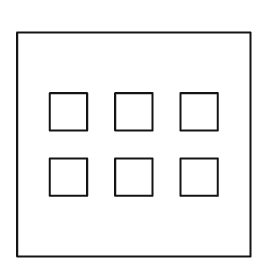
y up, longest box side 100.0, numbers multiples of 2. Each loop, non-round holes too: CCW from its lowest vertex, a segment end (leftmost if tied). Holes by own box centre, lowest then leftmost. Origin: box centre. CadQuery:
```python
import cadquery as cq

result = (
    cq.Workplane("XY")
    .moveTo(-50.0, -48.0)
    .lineTo(50.0, -48.0)
    .lineTo(50.0, 48.0)
    .lineTo(-50.0, 48.0)
    .close()
    .moveTo(-36.0, -22.0)
    .lineTo(-20.0, -22.0)
    .lineTo(-20.0, -6.0)
    .lineTo(-36.0, -6.0)
    .close()
    .moveTo(-8.0, -22.0)
    .lineTo(8.0, -22.0)
    .lineTo(8.0, -6.0)
    .lineTo(-8.0, -6.0)
    .close()
    .moveTo(20.0, -22.0)
    .lineTo(36.0, -22.0)
    .lineTo(36.0, -6.0)
    .lineTo(20.0, -6.0)
    .close()
    .moveTo(-36.0, 6.0)
    .lineTo(-20.0, 6.0)
    .lineTo(-20.0, 22.0)
    .lineTo(-36.0, 22.0)
    .close()
    .moveTo(-8.0, 6.0)
    .lineTo(8.0, 6.0)
    .lineTo(8.0, 22.0)
    .lineTo(-8.0, 22.0)
    .close()
    .moveTo(20.0, 6.0)
    .lineTo(36.0, 6.0)
    .lineTo(36.0, 22.0)
    .lineTo(20.0, 22.0)
    .close()
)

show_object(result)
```